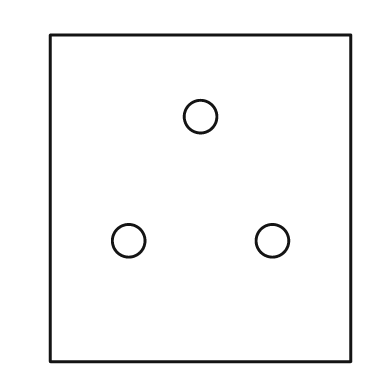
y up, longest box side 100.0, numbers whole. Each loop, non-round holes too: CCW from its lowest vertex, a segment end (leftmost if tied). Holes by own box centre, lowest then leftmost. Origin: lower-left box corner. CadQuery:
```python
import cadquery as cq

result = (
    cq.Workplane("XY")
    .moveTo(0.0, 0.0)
    .lineTo(92.0, 0.0)
    .lineTo(92.0, 100.0)
    .lineTo(0.0, 100.0)
    .close()
    .moveTo(24.0, 37.0)
    .circle(5.0)
    .moveTo(68.0, 37.0)
    .circle(5.0)
    .moveTo(46.0, 75.0)
    .circle(5.0)
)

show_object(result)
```